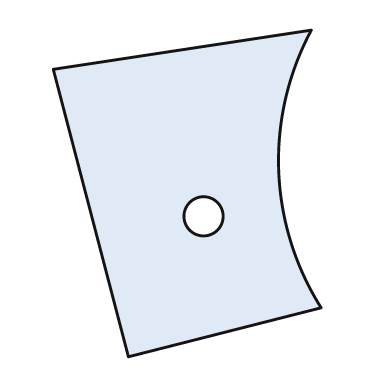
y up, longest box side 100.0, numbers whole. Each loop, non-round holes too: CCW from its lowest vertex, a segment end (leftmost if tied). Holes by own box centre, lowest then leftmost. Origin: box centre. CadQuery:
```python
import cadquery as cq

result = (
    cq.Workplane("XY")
    .moveTo(-18.0, -50.0)
    .lineTo(41.0, -35.0)
    .threePointArc((28.0, 7.0), (38.0, 50.0))
    .lineTo(-41.0, 38.0)
    .close()
    .moveTo(5.0, -7.0)
    .circle(6.0)
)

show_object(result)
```